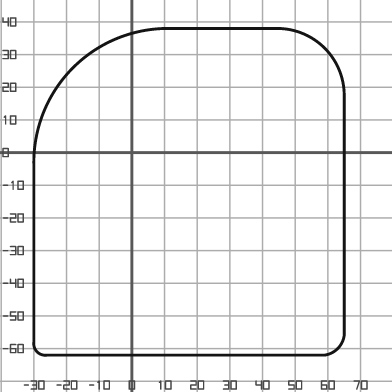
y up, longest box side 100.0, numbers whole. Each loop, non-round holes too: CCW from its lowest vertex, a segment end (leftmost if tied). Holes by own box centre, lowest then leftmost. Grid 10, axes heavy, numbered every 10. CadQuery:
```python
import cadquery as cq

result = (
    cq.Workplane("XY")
    .moveTo(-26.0, -62.0)
    .lineTo(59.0, -62.0)
    .threePointArc((63.0, -60.0), (65.0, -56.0))
    .lineTo(65.0, 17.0)
    .threePointArc((59.0, 32.0), (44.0, 38.0))
    .lineTo(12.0, 38.0)
    .threePointArc((-18.0, 26.0), (-30.0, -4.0))
    .lineTo(-30.0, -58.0)
    .threePointArc((-29.0, -61.0), (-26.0, -62.0))
    .close()
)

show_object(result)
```